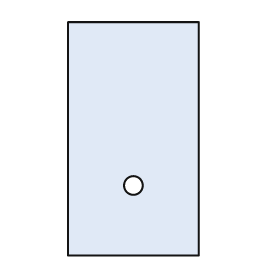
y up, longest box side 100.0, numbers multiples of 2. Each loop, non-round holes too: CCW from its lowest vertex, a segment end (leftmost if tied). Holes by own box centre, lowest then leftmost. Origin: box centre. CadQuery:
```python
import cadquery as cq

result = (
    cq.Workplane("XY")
    .moveTo(-28.0, -50.0)
    .lineTo(28.0, -50.0)
    .lineTo(28.0, 50.0)
    .lineTo(-28.0, 50.0)
    .close()
    .moveTo(0.0, -20.0)
    .circle(4.0)
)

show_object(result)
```